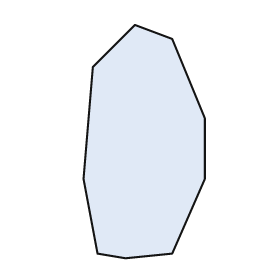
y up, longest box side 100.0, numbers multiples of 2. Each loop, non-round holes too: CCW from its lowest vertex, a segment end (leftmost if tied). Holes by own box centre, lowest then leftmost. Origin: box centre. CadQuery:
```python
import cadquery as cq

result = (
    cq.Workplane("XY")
    .moveTo(-8.0, -50.0)
    .lineTo(12.0, -48.0)
    .lineTo(26.0, -16.0)
    .lineTo(26.0, 10.0)
    .lineTo(12.0, 44.0)
    .lineTo(-4.0, 50.0)
    .lineTo(-22.0, 32.0)
    .lineTo(-26.0, -16.0)
    .lineTo(-20.0, -48.0)
    .close()
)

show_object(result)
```